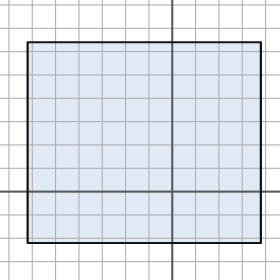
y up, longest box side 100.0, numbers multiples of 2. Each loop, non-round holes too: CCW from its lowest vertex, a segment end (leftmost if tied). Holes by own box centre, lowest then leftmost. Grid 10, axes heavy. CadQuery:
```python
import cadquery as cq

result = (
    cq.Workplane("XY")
    .moveTo(-62.0, -22.0)
    .lineTo(38.0, -22.0)
    .lineTo(38.0, 64.0)
    .lineTo(-62.0, 64.0)
    .close()
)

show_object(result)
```